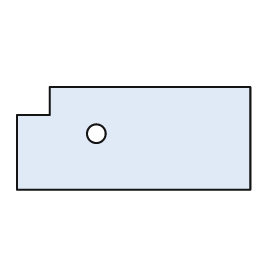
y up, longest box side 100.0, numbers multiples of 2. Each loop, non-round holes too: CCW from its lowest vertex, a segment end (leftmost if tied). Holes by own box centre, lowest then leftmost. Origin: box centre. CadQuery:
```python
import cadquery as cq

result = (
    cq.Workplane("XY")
    .moveTo(-50.0, -22.0)
    .lineTo(50.0, -22.0)
    .lineTo(50.0, 22.0)
    .lineTo(-36.0, 22.0)
    .lineTo(-36.0, 10.0)
    .lineTo(-50.0, 10.0)
    .close()
    .moveTo(-16.0, 2.0)
    .circle(4.0)
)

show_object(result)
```